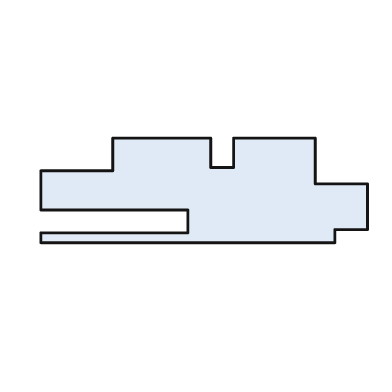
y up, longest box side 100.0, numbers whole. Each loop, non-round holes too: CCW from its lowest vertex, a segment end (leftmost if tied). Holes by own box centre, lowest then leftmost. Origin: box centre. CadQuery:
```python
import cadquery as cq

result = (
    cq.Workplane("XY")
    .moveTo(-50.0, -16.0)
    .lineTo(40.0, -16.0)
    .lineTo(40.0, -12.0)
    .lineTo(50.0, -12.0)
    .lineTo(50.0, 2.0)
    .lineTo(34.0, 2.0)
    .lineTo(34.0, 16.0)
    .lineTo(9.0, 16.0)
    .lineTo(9.0, 7.0)
    .lineTo(2.0, 7.0)
    .lineTo(2.0, 16.0)
    .lineTo(-28.0, 16.0)
    .lineTo(-28.0, 6.0)
    .lineTo(-50.0, 6.0)
    .lineTo(-50.0, -6.0)
    .lineTo(-5.0, -6.0)
    .lineTo(-5.0, -13.0)
    .lineTo(-50.0, -13.0)
    .close()
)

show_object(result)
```